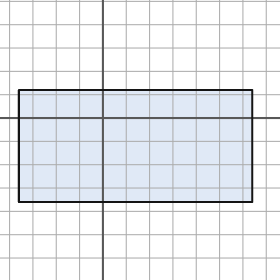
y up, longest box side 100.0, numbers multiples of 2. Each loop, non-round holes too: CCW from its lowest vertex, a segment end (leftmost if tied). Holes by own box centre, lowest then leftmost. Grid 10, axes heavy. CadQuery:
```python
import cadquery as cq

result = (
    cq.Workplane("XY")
    .moveTo(-36.0, -36.0)
    .lineTo(64.0, -36.0)
    .lineTo(64.0, 12.0)
    .lineTo(-36.0, 12.0)
    .close()
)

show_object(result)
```